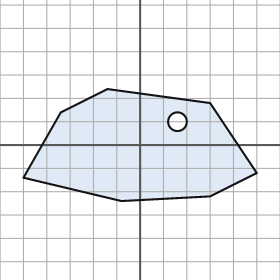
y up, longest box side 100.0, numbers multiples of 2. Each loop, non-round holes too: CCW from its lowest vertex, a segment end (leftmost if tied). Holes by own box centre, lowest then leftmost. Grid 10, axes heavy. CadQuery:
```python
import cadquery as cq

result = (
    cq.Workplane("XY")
    .moveTo(-8.0, -24.0)
    .lineTo(30.0, -22.0)
    .lineTo(50.0, -12.0)
    .lineTo(30.0, 18.0)
    .lineTo(-14.0, 24.0)
    .lineTo(-34.0, 14.0)
    .lineTo(-50.0, -14.0)
    .close()
    .moveTo(16.0, 10.0)
    .circle(4.0)
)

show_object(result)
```